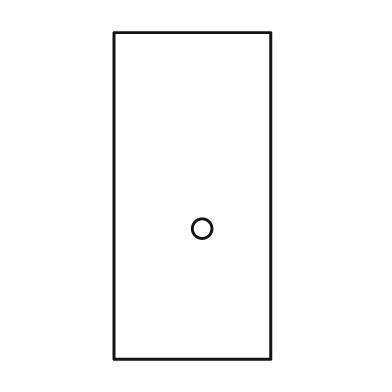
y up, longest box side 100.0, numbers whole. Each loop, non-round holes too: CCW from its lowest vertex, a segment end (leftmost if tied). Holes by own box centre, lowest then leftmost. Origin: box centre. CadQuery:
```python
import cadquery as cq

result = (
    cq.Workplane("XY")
    .moveTo(-24.0, -50.0)
    .lineTo(24.0, -50.0)
    .lineTo(24.0, 50.0)
    .lineTo(-24.0, 50.0)
    .close()
    .moveTo(3.0, -10.0)
    .circle(3.0)
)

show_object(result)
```